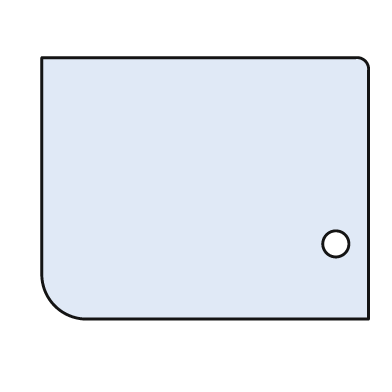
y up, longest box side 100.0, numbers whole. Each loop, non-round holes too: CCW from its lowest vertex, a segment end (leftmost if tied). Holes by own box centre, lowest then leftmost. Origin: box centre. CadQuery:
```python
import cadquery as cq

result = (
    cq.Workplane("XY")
    .moveTo(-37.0, -40.0)
    .lineTo(50.0, -40.0)
    .lineTo(50.0, 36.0)
    .threePointArc((49.0, 39.0), (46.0, 40.0))
    .lineTo(-50.0, 40.0)
    .lineTo(-50.0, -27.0)
    .threePointArc((-46.0, -36.0), (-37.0, -40.0))
    .close()
    .moveTo(40.0, -17.0)
    .circle(4.0)
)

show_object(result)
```